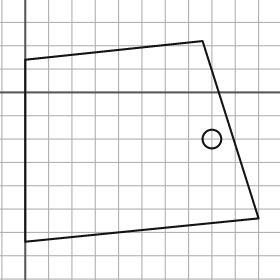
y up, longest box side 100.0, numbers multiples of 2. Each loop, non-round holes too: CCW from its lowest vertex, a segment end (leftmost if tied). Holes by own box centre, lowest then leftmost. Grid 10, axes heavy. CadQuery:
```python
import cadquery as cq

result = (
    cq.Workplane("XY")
    .moveTo(0.0, -64.0)
    .lineTo(100.0, -54.0)
    .lineTo(76.0, 22.0)
    .lineTo(0.0, 14.0)
    .close()
    .moveTo(80.0, -20.0)
    .circle(4.0)
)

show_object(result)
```